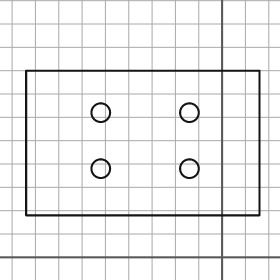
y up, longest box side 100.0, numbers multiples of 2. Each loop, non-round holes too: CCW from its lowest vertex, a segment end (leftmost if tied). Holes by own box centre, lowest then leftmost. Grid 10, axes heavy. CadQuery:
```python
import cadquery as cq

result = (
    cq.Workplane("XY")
    .moveTo(-84.0, 18.0)
    .lineTo(16.0, 18.0)
    .lineTo(16.0, 80.0)
    .lineTo(-84.0, 80.0)
    .close()
    .moveTo(-52.0, 38.0)
    .circle(4.0)
    .moveTo(-14.0, 38.0)
    .circle(4.0)
    .moveTo(-52.0, 62.0)
    .circle(4.0)
    .moveTo(-14.0, 62.0)
    .circle(4.0)
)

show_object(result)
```